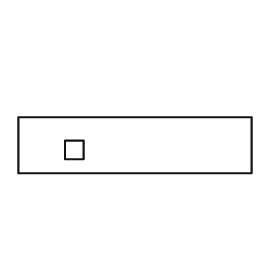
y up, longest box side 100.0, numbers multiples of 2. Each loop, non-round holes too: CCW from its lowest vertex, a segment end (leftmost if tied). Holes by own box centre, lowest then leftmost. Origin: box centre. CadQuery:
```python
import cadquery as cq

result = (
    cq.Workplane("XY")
    .moveTo(-50.0, -12.0)
    .lineTo(50.0, -12.0)
    .lineTo(50.0, 12.0)
    .lineTo(-50.0, 12.0)
    .close()
    .moveTo(-30.0, -6.0)
    .lineTo(-22.0, -6.0)
    .lineTo(-22.0, 2.0)
    .lineTo(-30.0, 2.0)
    .close()
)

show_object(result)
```